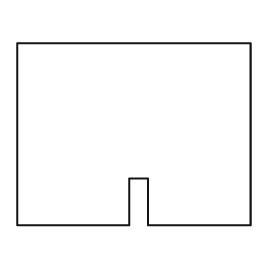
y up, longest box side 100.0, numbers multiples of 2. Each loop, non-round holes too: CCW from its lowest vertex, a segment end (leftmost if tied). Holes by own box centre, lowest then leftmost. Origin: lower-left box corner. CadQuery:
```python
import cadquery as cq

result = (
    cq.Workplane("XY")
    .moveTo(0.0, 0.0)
    .lineTo(48.0, 0.0)
    .lineTo(48.0, 20.0)
    .lineTo(56.0, 20.0)
    .lineTo(56.0, 0.0)
    .lineTo(100.0, 0.0)
    .lineTo(100.0, 78.0)
    .lineTo(0.0, 78.0)
    .close()
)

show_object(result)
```